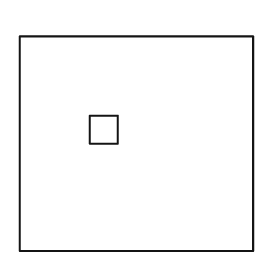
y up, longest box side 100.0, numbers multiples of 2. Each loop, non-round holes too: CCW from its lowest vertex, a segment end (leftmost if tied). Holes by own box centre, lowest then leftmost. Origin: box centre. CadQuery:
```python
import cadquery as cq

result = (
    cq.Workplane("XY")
    .moveTo(-50.0, -46.0)
    .lineTo(50.0, -46.0)
    .lineTo(50.0, 46.0)
    .lineTo(-50.0, 46.0)
    .close()
    .moveTo(-20.0, 0.0)
    .lineTo(-8.0, 0.0)
    .lineTo(-8.0, 12.0)
    .lineTo(-20.0, 12.0)
    .close()
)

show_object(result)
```